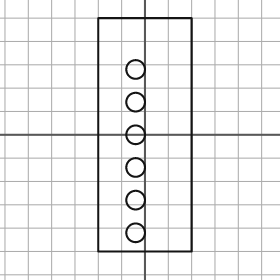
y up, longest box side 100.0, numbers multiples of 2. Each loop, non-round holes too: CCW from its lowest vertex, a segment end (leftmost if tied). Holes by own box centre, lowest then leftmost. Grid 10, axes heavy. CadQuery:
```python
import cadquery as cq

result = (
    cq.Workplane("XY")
    .moveTo(-20.0, -50.0)
    .lineTo(20.0, -50.0)
    .lineTo(20.0, 50.0)
    .lineTo(-20.0, 50.0)
    .close()
    .moveTo(-4.0, -42.0)
    .circle(4.0)
    .moveTo(-4.0, -28.0)
    .circle(4.0)
    .moveTo(-4.0, -14.0)
    .circle(4.0)
    .moveTo(-4.0, 0.0)
    .circle(4.0)
    .moveTo(-4.0, 14.0)
    .circle(4.0)
    .moveTo(-4.0, 28.0)
    .circle(4.0)
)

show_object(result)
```